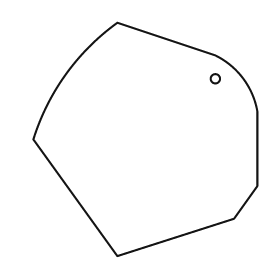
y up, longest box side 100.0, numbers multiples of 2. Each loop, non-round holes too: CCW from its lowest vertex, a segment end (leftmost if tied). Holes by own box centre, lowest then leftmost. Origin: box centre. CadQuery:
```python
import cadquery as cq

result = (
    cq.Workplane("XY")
    .moveTo(-12.0, -50.0)
    .lineTo(38.0, -34.0)
    .lineTo(48.0, -20.0)
    .lineTo(48.0, 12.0)
    .threePointArc((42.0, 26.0), (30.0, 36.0))
    .lineTo(-12.0, 50.0)
    .threePointArc((-34.0, 28.0), (-48.0, 0.0))
    .close()
    .moveTo(30.0, 26.0)
    .circle(2.0)
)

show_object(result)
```